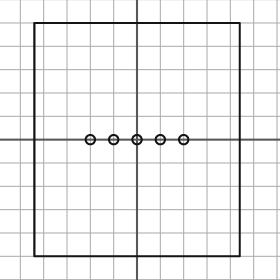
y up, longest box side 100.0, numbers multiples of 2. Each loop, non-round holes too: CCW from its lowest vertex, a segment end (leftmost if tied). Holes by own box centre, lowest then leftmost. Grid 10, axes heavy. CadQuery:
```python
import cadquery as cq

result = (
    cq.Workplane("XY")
    .moveTo(-44.0, -50.0)
    .lineTo(44.0, -50.0)
    .lineTo(44.0, 50.0)
    .lineTo(-44.0, 50.0)
    .close()
    .moveTo(-20.0, 0.0)
    .circle(2.0)
    .moveTo(-10.0, 0.0)
    .circle(2.0)
    .moveTo(0.0, 0.0)
    .circle(2.0)
    .moveTo(10.0, 0.0)
    .circle(2.0)
    .moveTo(20.0, 0.0)
    .circle(2.0)
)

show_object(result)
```